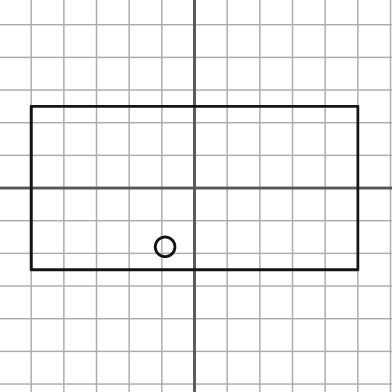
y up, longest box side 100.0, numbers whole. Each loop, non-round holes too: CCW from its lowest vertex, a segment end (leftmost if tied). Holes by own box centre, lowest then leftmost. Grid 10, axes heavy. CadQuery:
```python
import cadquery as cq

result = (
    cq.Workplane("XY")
    .moveTo(-50.0, -25.0)
    .lineTo(50.0, -25.0)
    .lineTo(50.0, 25.0)
    .lineTo(-50.0, 25.0)
    .close()
    .moveTo(-9.0, -18.0)
    .circle(3.0)
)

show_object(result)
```